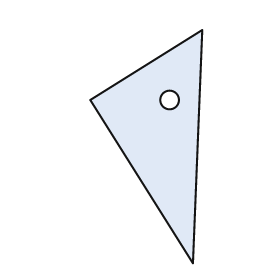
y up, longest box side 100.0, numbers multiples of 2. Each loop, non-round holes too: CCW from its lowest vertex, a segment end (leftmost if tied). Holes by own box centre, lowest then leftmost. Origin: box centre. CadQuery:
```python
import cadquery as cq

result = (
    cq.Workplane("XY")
    .moveTo(20.0, -50.0)
    .lineTo(24.0, 50.0)
    .lineTo(-24.0, 20.0)
    .close()
    .moveTo(10.0, 20.0)
    .circle(4.0)
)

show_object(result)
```